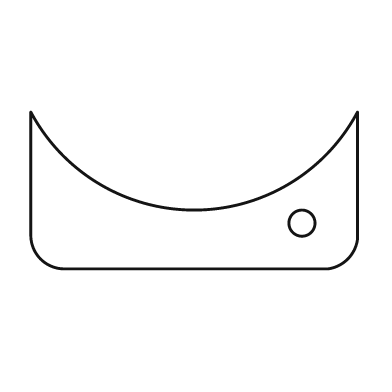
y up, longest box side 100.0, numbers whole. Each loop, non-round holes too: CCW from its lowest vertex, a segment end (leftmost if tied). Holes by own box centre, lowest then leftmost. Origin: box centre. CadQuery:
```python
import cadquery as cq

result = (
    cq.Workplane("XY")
    .moveTo(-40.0, -24.0)
    .lineTo(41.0, -24.0)
    .threePointArc((47.0, -21.0), (50.0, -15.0))
    .lineTo(50.0, 24.0)
    .threePointArc((0.0, -6.0), (-50.0, 24.0))
    .lineTo(-50.0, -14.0)
    .threePointArc((-47.0, -21.0), (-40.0, -24.0))
    .close()
    .moveTo(33.0, -10.0)
    .circle(4.0)
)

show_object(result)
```